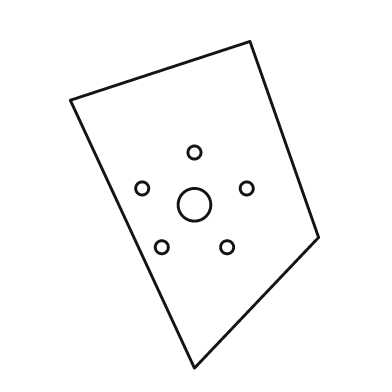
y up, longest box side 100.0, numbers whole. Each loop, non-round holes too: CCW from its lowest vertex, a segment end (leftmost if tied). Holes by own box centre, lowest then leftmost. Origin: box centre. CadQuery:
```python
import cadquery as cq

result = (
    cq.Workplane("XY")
    .moveTo(0.0, -50.0)
    .lineTo(38.0, -10.0)
    .lineTo(17.0, 50.0)
    .lineTo(-38.0, 32.0)
    .close()
    .moveTo(-10.0, -13.0)
    .circle(2.0)
    .moveTo(10.0, -13.0)
    .circle(2.0)
    .moveTo(0.0, 0.0)
    .circle(5.0)
    .moveTo(-16.0, 5.0)
    .circle(2.0)
    .moveTo(16.0, 5.0)
    .circle(2.0)
    .moveTo(0.0, 16.0)
    .circle(2.0)
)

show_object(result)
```